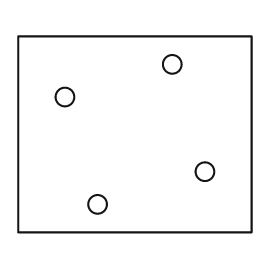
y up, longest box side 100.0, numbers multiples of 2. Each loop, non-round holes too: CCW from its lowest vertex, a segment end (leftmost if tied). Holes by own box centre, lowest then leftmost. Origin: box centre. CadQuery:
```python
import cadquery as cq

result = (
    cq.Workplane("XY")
    .moveTo(-50.0, -42.0)
    .lineTo(50.0, -42.0)
    .lineTo(50.0, 42.0)
    .lineTo(-50.0, 42.0)
    .close()
    .moveTo(-16.0, -30.0)
    .circle(4.0)
    .moveTo(30.0, -16.0)
    .circle(4.0)
    .moveTo(-30.0, 16.0)
    .circle(4.0)
    .moveTo(16.0, 30.0)
    .circle(4.0)
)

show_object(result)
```